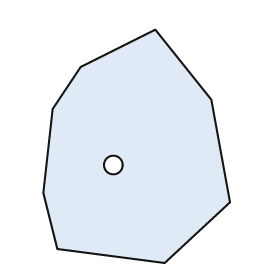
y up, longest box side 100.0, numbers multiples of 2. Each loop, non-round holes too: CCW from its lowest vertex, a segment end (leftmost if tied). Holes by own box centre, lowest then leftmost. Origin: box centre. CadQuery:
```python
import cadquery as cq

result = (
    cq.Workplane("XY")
    .moveTo(12.0, -50.0)
    .lineTo(40.0, -24.0)
    .lineTo(32.0, 20.0)
    .lineTo(8.0, 50.0)
    .lineTo(-24.0, 34.0)
    .lineTo(-36.0, 16.0)
    .lineTo(-40.0, -20.0)
    .lineTo(-34.0, -44.0)
    .close()
    .moveTo(-10.0, -8.0)
    .circle(4.0)
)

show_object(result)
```